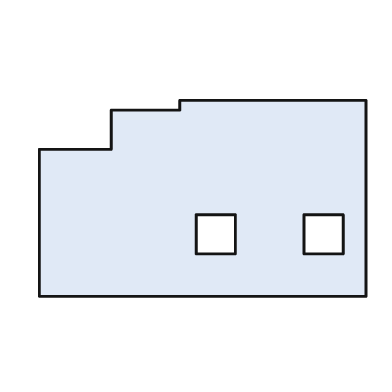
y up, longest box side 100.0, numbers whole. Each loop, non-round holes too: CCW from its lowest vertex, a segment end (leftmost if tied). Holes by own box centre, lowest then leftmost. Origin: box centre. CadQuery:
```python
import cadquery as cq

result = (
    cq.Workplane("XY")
    .moveTo(-50.0, -30.0)
    .lineTo(50.0, -30.0)
    .lineTo(50.0, 30.0)
    .lineTo(-7.0, 30.0)
    .lineTo(-7.0, 27.0)
    .lineTo(-28.0, 27.0)
    .lineTo(-28.0, 15.0)
    .lineTo(-50.0, 15.0)
    .close()
    .moveTo(-2.0, -17.0)
    .lineTo(10.0, -17.0)
    .lineTo(10.0, -5.0)
    .lineTo(-2.0, -5.0)
    .close()
    .moveTo(31.0, -17.0)
    .lineTo(43.0, -17.0)
    .lineTo(43.0, -5.0)
    .lineTo(31.0, -5.0)
    .close()
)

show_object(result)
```